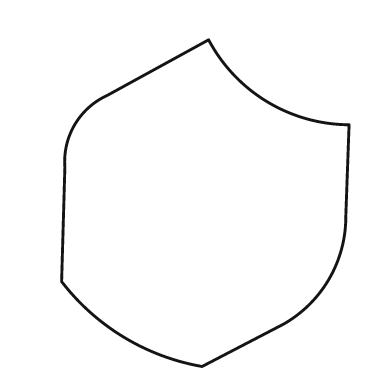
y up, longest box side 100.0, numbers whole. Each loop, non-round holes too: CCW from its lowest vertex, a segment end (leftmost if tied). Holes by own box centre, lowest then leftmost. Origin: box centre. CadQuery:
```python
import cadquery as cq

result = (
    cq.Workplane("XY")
    .moveTo(-1.0, -50.0)
    .lineTo(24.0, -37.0)
    .threePointArc((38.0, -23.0), (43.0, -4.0))
    .lineTo(44.0, 24.0)
    .threePointArc((19.0, 31.0), (1.0, 50.0))
    .lineTo(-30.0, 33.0)
    .threePointArc((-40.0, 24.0), (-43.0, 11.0))
    .lineTo(-44.0, -24.0)
    .threePointArc((-25.0, -41.0), (-1.0, -50.0))
    .close()
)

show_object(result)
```